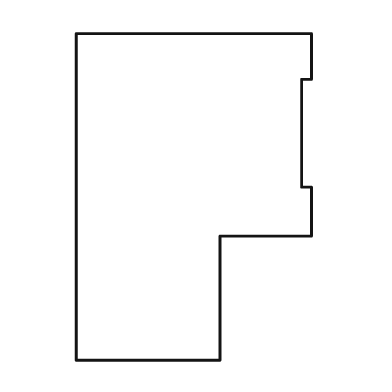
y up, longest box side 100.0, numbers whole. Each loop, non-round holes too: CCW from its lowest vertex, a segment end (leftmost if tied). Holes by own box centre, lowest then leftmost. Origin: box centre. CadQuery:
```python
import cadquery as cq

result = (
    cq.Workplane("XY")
    .moveTo(-36.0, -50.0)
    .lineTo(8.0, -50.0)
    .lineTo(8.0, -12.0)
    .lineTo(36.0, -12.0)
    .lineTo(36.0, 3.0)
    .lineTo(33.0, 3.0)
    .lineTo(33.0, 36.0)
    .lineTo(36.0, 36.0)
    .lineTo(36.0, 50.0)
    .lineTo(-36.0, 50.0)
    .close()
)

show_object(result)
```